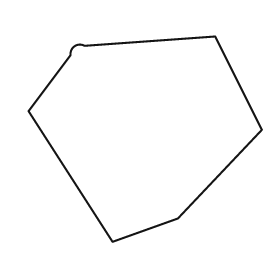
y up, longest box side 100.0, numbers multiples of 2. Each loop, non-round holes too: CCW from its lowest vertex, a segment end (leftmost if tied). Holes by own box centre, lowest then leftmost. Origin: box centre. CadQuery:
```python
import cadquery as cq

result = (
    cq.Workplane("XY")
    .moveTo(-14.0, -44.0)
    .lineTo(14.0, -34.0)
    .lineTo(50.0, 4.0)
    .lineTo(30.0, 44.0)
    .lineTo(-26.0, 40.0)
    .threePointArc((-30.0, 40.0), (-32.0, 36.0))
    .lineTo(-50.0, 12.0)
    .close()
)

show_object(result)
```